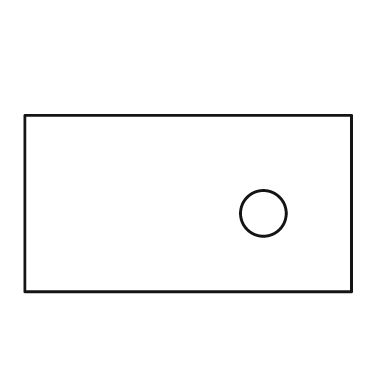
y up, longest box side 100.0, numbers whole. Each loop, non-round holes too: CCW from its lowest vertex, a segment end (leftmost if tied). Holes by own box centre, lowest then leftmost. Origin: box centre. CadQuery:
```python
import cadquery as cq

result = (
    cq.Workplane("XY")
    .moveTo(-50.0, -27.0)
    .lineTo(50.0, -27.0)
    .lineTo(50.0, 27.0)
    .lineTo(-50.0, 27.0)
    .close()
    .moveTo(23.0, -3.0)
    .circle(7.0)
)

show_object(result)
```